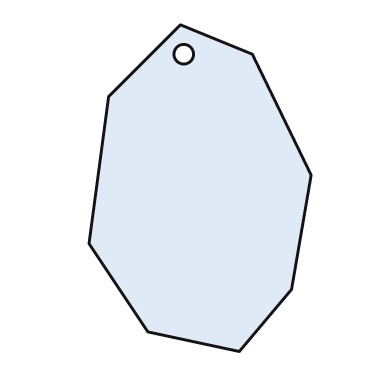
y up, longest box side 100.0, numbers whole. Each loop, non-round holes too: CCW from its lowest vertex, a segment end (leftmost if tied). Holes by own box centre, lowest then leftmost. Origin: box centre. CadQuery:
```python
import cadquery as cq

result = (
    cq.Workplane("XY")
    .moveTo(12.0, -50.0)
    .lineTo(28.0, -31.0)
    .lineTo(34.0, 4.0)
    .lineTo(16.0, 41.0)
    .lineTo(-6.0, 50.0)
    .lineTo(-28.0, 28.0)
    .lineTo(-34.0, -17.0)
    .lineTo(-16.0, -44.0)
    .close()
    .moveTo(-5.0, 41.0)
    .circle(3.0)
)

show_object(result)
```